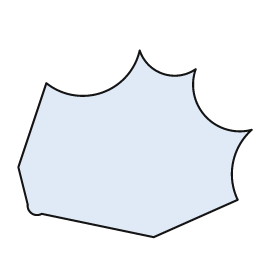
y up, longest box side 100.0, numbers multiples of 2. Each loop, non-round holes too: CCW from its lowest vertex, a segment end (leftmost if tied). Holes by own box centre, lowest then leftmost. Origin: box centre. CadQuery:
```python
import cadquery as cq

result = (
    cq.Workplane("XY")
    .moveTo(8.0, -40.0)
    .lineTo(44.0, -24.0)
    .threePointArc((42.0, -8.0), (50.0, 6.0))
    .threePointArc((30.0, 12.0), (26.0, 32.0))
    .threePointArc((12.0, 30.0), (2.0, 40.0))
    .threePointArc((-14.0, 22.0), (-38.0, 26.0))
    .lineTo(-50.0, -10.0)
    .lineTo(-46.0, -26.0)
    .threePointArc((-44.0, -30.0), (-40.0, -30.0))
    .close()
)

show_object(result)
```